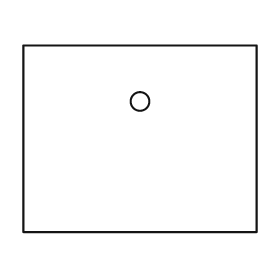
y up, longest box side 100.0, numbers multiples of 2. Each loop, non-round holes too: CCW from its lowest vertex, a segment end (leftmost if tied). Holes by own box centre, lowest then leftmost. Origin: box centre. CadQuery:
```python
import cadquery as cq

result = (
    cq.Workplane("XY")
    .moveTo(-50.0, -40.0)
    .lineTo(50.0, -40.0)
    .lineTo(50.0, 40.0)
    .lineTo(-50.0, 40.0)
    .close()
    .moveTo(0.0, 16.0)
    .circle(4.0)
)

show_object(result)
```